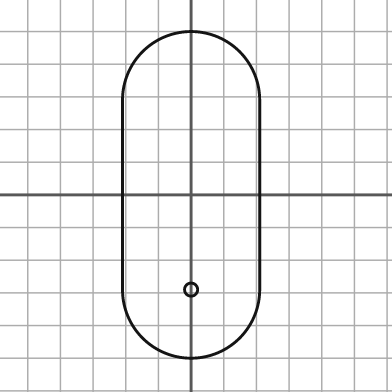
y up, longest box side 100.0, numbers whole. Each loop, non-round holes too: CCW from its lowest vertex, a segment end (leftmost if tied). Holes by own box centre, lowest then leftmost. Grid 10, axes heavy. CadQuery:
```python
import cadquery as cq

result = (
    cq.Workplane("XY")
    .moveTo(-21.0, -29.0)
    .threePointArc((0.0, -50.0), (21.0, -29.0))
    .lineTo(21.0, 29.0)
    .threePointArc((0.0, 50.0), (-21.0, 29.0))
    .close()
    .moveTo(0.0, -29.0)
    .circle(2.0)
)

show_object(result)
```